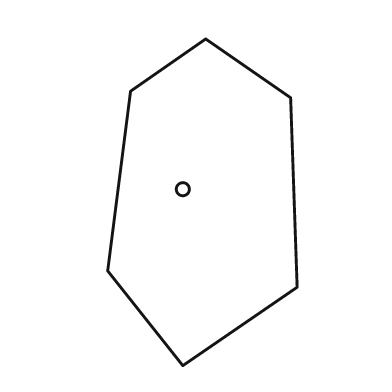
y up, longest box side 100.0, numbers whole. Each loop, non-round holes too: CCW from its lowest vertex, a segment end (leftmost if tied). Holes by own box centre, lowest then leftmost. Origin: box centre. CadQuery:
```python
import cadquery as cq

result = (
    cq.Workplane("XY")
    .moveTo(-6.0, -50.0)
    .lineTo(29.0, -26.0)
    .lineTo(27.0, 32.0)
    .lineTo(1.0, 50.0)
    .lineTo(-22.0, 34.0)
    .lineTo(-29.0, -21.0)
    .close()
    .moveTo(-6.0, 4.0)
    .circle(2.0)
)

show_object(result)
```